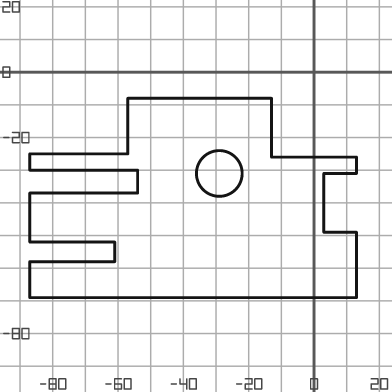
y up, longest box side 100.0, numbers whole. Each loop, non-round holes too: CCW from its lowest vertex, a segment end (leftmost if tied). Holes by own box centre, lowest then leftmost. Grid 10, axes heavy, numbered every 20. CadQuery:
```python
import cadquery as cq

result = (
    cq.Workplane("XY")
    .moveTo(-87.0, -69.0)
    .lineTo(13.0, -69.0)
    .lineTo(13.0, -49.0)
    .lineTo(3.0, -49.0)
    .lineTo(3.0, -31.0)
    .lineTo(13.0, -31.0)
    .lineTo(13.0, -26.0)
    .lineTo(-13.0, -26.0)
    .lineTo(-13.0, -8.0)
    .lineTo(-57.0, -8.0)
    .lineTo(-57.0, -25.0)
    .lineTo(-87.0, -25.0)
    .lineTo(-87.0, -30.0)
    .lineTo(-54.0, -30.0)
    .lineTo(-54.0, -37.0)
    .lineTo(-87.0, -37.0)
    .lineTo(-87.0, -52.0)
    .lineTo(-61.0, -52.0)
    .lineTo(-61.0, -58.0)
    .lineTo(-87.0, -58.0)
    .close()
    .moveTo(-29.0, -31.0)
    .circle(7.0)
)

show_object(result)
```